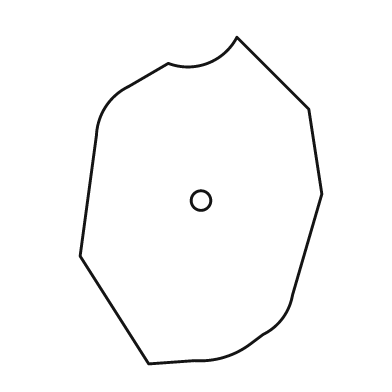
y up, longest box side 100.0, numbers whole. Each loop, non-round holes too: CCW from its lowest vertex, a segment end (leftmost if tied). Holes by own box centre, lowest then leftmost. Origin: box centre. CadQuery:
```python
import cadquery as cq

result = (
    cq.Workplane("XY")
    .moveTo(-16.0, -50.0)
    .lineTo(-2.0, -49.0)
    .threePointArc((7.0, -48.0), (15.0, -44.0))
    .lineTo(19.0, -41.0)
    .threePointArc((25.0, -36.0), (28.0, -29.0))
    .lineTo(37.0, 2.0)
    .lineTo(33.0, 28.0)
    .lineTo(11.0, 50.0)
    .threePointArc((2.0, 42.0), (-10.0, 42.0))
    .lineTo(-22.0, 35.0)
    .threePointArc((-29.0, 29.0), (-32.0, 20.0))
    .lineTo(-37.0, -17.0)
    .close()
    .moveTo(0.0, 0.0)
    .circle(3.0)
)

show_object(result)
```